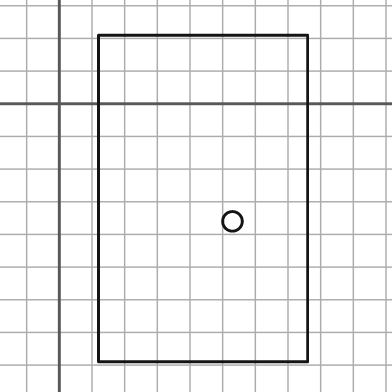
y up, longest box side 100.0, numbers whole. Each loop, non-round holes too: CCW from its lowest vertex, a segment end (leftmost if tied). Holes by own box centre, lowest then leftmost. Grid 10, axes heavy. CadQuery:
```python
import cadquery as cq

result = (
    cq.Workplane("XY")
    .moveTo(12.0, -79.0)
    .lineTo(76.0, -79.0)
    .lineTo(76.0, 21.0)
    .lineTo(12.0, 21.0)
    .close()
    .moveTo(53.0, -36.0)
    .circle(3.0)
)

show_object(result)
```